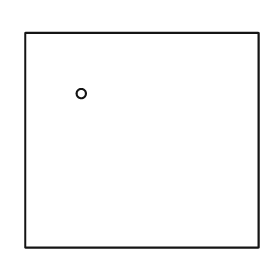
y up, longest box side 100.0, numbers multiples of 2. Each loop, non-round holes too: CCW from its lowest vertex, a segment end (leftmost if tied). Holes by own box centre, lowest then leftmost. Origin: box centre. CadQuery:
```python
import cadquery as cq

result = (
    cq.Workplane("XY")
    .moveTo(-50.0, -46.0)
    .lineTo(50.0, -46.0)
    .lineTo(50.0, 46.0)
    .lineTo(-50.0, 46.0)
    .close()
    .moveTo(-26.0, 20.0)
    .circle(2.0)
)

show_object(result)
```